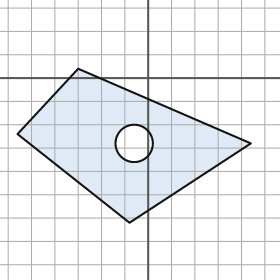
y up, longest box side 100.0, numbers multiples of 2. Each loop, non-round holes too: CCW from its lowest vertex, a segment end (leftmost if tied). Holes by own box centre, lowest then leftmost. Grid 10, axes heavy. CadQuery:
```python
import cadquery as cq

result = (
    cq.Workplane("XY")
    .moveTo(-8.0, -62.0)
    .lineTo(44.0, -28.0)
    .lineTo(-30.0, 4.0)
    .lineTo(-56.0, -24.0)
    .close()
    .moveTo(-6.0, -28.0)
    .circle(8.0)
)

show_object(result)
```